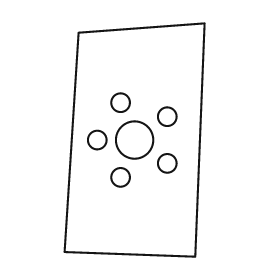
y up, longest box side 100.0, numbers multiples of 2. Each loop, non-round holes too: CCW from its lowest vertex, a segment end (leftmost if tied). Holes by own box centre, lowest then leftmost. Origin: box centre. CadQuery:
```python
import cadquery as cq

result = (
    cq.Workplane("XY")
    .moveTo(26.0, -50.0)
    .lineTo(30.0, 50.0)
    .lineTo(-24.0, 46.0)
    .lineTo(-30.0, -48.0)
    .close()
    .moveTo(-6.0, -16.0)
    .circle(4.0)
    .moveTo(14.0, -10.0)
    .circle(4.0)
    .moveTo(-16.0, 0.0)
    .circle(4.0)
    .moveTo(0.0, 0.0)
    .circle(8.0)
    .moveTo(14.0, 10.0)
    .circle(4.0)
    .moveTo(-6.0, 16.0)
    .circle(4.0)
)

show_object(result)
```